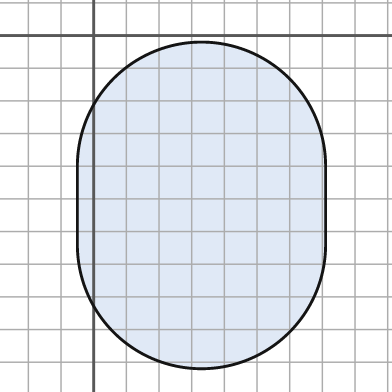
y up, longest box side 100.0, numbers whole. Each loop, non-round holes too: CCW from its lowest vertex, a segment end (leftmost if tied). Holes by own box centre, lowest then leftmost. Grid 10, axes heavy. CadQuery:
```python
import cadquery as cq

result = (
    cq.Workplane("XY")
    .moveTo(-5.0, -64.0)
    .threePointArc((33.0, -102.0), (71.0, -64.0))
    .lineTo(71.0, -40.0)
    .threePointArc((33.0, -2.0), (-5.0, -40.0))
    .close()
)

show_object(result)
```